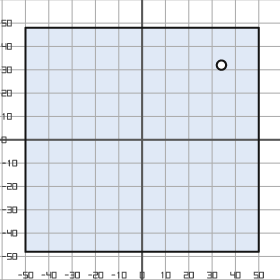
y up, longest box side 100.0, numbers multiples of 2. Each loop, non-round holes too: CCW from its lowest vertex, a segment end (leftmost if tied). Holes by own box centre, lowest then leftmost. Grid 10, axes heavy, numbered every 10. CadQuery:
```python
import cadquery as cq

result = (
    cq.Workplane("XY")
    .moveTo(-50.0, -48.0)
    .lineTo(50.0, -48.0)
    .lineTo(50.0, 48.0)
    .lineTo(-50.0, 48.0)
    .close()
    .moveTo(34.0, 32.0)
    .circle(2.0)
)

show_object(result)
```